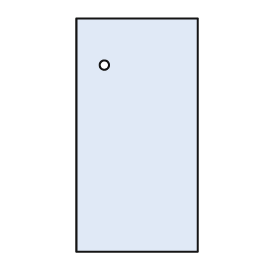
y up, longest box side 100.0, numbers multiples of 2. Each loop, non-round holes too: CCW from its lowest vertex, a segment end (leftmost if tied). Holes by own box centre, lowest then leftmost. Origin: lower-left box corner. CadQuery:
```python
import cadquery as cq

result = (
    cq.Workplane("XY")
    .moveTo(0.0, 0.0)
    .lineTo(52.0, 0.0)
    .lineTo(52.0, 100.0)
    .lineTo(0.0, 100.0)
    .close()
    .moveTo(12.0, 80.0)
    .circle(2.0)
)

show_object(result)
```